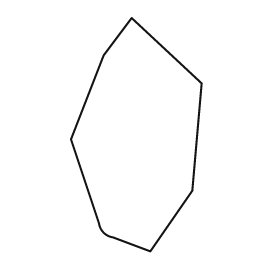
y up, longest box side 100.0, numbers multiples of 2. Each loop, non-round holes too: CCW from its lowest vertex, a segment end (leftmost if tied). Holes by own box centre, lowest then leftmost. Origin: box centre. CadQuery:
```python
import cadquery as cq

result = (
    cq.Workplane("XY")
    .moveTo(6.0, -50.0)
    .lineTo(24.0, -24.0)
    .lineTo(28.0, 22.0)
    .lineTo(-2.0, 50.0)
    .lineTo(-14.0, 34.0)
    .lineTo(-28.0, -2.0)
    .lineTo(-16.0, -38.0)
    .threePointArc((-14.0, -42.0), (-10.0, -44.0))
    .close()
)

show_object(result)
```